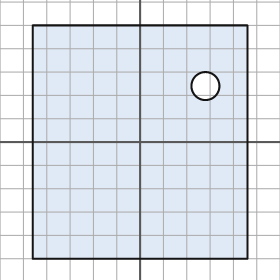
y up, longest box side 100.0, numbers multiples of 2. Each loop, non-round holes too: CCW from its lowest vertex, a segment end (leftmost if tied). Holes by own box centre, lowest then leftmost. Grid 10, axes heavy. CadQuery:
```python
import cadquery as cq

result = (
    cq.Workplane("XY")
    .moveTo(-46.0, -50.0)
    .lineTo(46.0, -50.0)
    .lineTo(46.0, 50.0)
    .lineTo(-46.0, 50.0)
    .close()
    .moveTo(28.0, 24.0)
    .circle(6.0)
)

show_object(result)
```